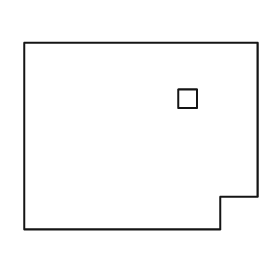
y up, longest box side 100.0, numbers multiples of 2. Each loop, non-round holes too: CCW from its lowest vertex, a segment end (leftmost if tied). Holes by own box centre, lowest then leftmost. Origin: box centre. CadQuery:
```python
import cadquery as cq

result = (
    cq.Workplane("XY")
    .moveTo(-50.0, -40.0)
    .lineTo(34.0, -40.0)
    .lineTo(34.0, -26.0)
    .lineTo(50.0, -26.0)
    .lineTo(50.0, 40.0)
    .lineTo(-50.0, 40.0)
    .close()
    .moveTo(16.0, 12.0)
    .lineTo(24.0, 12.0)
    .lineTo(24.0, 20.0)
    .lineTo(16.0, 20.0)
    .close()
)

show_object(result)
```